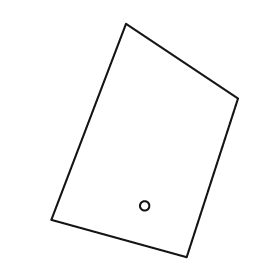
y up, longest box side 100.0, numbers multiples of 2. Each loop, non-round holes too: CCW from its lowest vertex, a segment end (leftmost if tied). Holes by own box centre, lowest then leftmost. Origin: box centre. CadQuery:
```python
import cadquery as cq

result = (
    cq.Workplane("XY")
    .moveTo(18.0, -50.0)
    .lineTo(40.0, 18.0)
    .lineTo(-8.0, 50.0)
    .lineTo(-40.0, -34.0)
    .close()
    .moveTo(0.0, -28.0)
    .circle(2.0)
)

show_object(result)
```